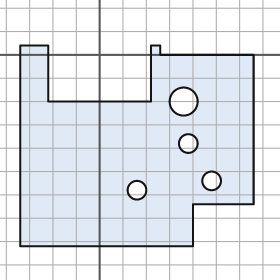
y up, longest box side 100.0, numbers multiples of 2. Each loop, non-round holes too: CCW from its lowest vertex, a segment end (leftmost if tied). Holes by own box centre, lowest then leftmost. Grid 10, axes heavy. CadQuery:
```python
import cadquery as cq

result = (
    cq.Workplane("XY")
    .moveTo(-34.0, -82.0)
    .lineTo(40.0, -82.0)
    .lineTo(40.0, -64.0)
    .lineTo(66.0, -64.0)
    .lineTo(66.0, 0.0)
    .lineTo(26.0, 0.0)
    .lineTo(26.0, 4.0)
    .lineTo(22.0, 4.0)
    .lineTo(22.0, -20.0)
    .lineTo(-22.0, -20.0)
    .lineTo(-22.0, 4.0)
    .lineTo(-34.0, 4.0)
    .close()
    .moveTo(16.0, -58.0)
    .circle(4.0)
    .moveTo(48.0, -54.0)
    .circle(4.0)
    .moveTo(38.0, -38.0)
    .circle(4.0)
    .moveTo(36.0, -20.0)
    .circle(6.0)
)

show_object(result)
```